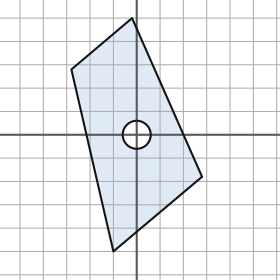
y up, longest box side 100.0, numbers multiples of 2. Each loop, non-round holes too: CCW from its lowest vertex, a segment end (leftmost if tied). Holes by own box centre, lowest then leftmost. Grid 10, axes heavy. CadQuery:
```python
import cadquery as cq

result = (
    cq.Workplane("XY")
    .moveTo(-10.0, -50.0)
    .lineTo(28.0, -18.0)
    .lineTo(-2.0, 50.0)
    .lineTo(-28.0, 28.0)
    .close()
    .moveTo(0.0, 0.0)
    .circle(6.0)
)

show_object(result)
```